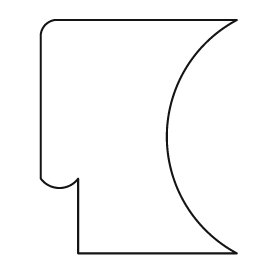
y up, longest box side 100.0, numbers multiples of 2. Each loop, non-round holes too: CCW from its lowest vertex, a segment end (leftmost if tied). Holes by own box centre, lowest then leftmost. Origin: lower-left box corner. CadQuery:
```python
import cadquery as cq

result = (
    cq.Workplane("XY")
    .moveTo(16.0, 0.0)
    .lineTo(84.0, 0.0)
    .threePointArc((54.0, 50.0), (84.0, 100.0))
    .lineTo(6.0, 100.0)
    .threePointArc((2.0, 98.0), (0.0, 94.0))
    .lineTo(0.0, 32.0)
    .threePointArc((8.0, 28.0), (16.0, 32.0))
    .close()
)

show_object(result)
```